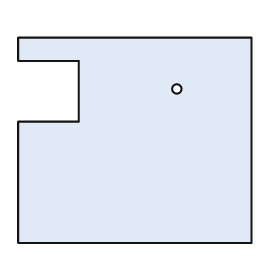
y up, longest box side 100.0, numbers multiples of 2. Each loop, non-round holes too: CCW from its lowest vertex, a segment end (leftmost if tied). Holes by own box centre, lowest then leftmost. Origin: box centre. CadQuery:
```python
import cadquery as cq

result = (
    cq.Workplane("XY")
    .moveTo(-50.0, -44.0)
    .lineTo(50.0, -44.0)
    .lineTo(50.0, 44.0)
    .lineTo(-50.0, 44.0)
    .lineTo(-50.0, 34.0)
    .lineTo(-24.0, 34.0)
    .lineTo(-24.0, 8.0)
    .lineTo(-50.0, 8.0)
    .close()
    .moveTo(18.0, 22.0)
    .circle(2.0)
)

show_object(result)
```